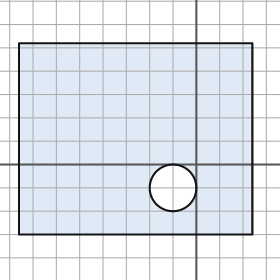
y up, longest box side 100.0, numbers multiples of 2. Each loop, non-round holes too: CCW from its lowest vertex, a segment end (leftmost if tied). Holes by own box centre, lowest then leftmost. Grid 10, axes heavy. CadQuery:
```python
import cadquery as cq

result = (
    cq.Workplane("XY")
    .moveTo(-76.0, -30.0)
    .lineTo(24.0, -30.0)
    .lineTo(24.0, 52.0)
    .lineTo(-76.0, 52.0)
    .close()
    .moveTo(-10.0, -10.0)
    .circle(10.0)
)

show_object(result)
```